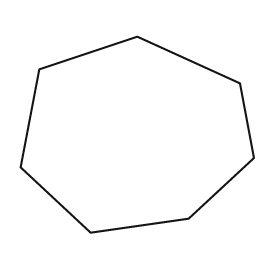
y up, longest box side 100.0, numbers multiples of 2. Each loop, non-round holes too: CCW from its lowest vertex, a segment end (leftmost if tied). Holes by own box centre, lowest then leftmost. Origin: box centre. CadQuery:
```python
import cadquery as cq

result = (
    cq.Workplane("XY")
    .moveTo(-20.0, -42.0)
    .lineTo(22.0, -36.0)
    .lineTo(50.0, -10.0)
    .lineTo(44.0, 22.0)
    .lineTo(0.0, 42.0)
    .lineTo(-42.0, 28.0)
    .lineTo(-50.0, -14.0)
    .close()
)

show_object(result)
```